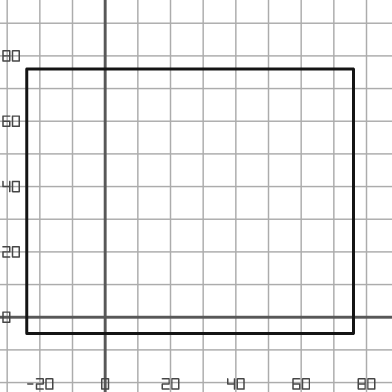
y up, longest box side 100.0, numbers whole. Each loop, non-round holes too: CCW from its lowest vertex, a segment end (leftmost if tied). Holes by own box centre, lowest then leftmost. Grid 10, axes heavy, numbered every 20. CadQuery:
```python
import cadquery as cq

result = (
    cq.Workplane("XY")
    .moveTo(-24.0, -5.0)
    .lineTo(76.0, -5.0)
    .lineTo(76.0, 76.0)
    .lineTo(-24.0, 76.0)
    .close()
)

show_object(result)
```